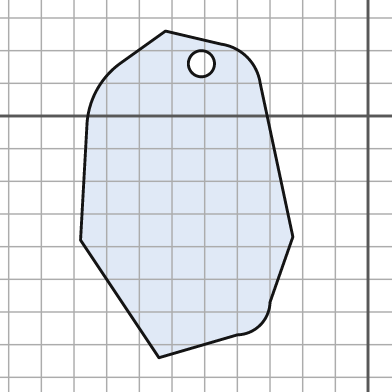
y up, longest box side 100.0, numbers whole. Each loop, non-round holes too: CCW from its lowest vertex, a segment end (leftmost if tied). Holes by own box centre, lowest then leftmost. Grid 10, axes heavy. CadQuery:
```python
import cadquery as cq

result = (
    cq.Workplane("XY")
    .moveTo(-64.0, -74.0)
    .lineTo(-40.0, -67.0)
    .threePointArc((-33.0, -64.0), (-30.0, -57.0))
    .lineTo(-23.0, -37.0)
    .lineTo(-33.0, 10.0)
    .threePointArc((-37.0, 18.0), (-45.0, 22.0))
    .lineTo(-62.0, 26.0)
    .lineTo(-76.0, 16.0)
    .threePointArc((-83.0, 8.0), (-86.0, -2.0))
    .lineTo(-88.0, -38.0)
    .close()
    .moveTo(-51.0, 16.0)
    .circle(4.0)
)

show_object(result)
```